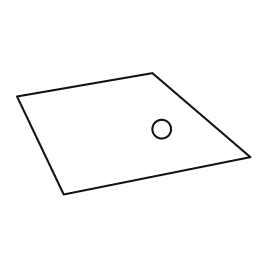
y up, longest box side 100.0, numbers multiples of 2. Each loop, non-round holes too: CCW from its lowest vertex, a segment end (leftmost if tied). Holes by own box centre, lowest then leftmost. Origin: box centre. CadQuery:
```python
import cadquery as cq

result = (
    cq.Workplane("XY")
    .moveTo(-30.0, -26.0)
    .lineTo(50.0, -10.0)
    .lineTo(8.0, 26.0)
    .lineTo(-50.0, 16.0)
    .close()
    .moveTo(12.0, 2.0)
    .circle(4.0)
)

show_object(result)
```